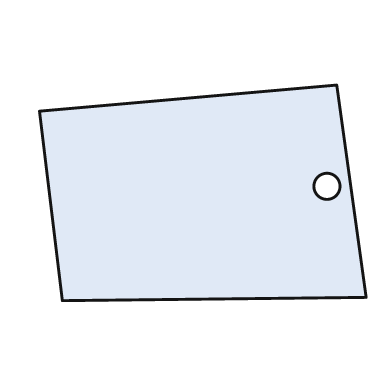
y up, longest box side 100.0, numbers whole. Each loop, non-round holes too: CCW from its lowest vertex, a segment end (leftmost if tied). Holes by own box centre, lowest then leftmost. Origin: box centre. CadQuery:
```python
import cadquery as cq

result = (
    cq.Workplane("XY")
    .moveTo(-43.0, -33.0)
    .lineTo(50.0, -32.0)
    .lineTo(41.0, 33.0)
    .lineTo(-50.0, 25.0)
    .close()
    .moveTo(38.0, 2.0)
    .circle(4.0)
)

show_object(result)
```